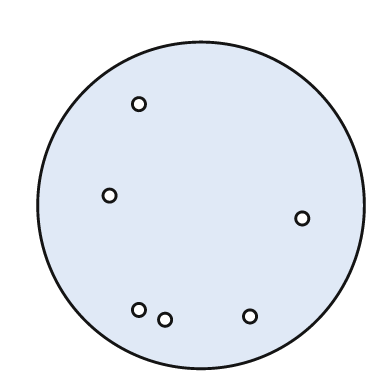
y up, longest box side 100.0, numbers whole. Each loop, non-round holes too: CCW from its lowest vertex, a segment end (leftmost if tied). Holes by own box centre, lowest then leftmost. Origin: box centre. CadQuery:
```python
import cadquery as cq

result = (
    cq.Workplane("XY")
    .moveTo(0.0, 0.0)
    .circle(50.0)
    .moveTo(-11.0, -35.0)
    .circle(2.0)
    .moveTo(15.0, -34.0)
    .circle(2.0)
    .moveTo(-19.0, -32.0)
    .circle(2.0)
    .moveTo(31.0, -4.0)
    .circle(2.0)
    .moveTo(-28.0, 3.0)
    .circle(2.0)
    .moveTo(-19.0, 31.0)
    .circle(2.0)
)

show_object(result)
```